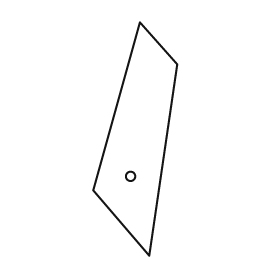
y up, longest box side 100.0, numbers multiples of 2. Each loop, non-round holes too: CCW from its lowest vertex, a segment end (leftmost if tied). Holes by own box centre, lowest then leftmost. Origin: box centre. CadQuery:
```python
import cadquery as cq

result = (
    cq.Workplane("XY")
    .moveTo(6.0, -50.0)
    .lineTo(18.0, 32.0)
    .lineTo(2.0, 50.0)
    .lineTo(-18.0, -22.0)
    .close()
    .moveTo(-2.0, -16.0)
    .circle(2.0)
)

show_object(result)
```